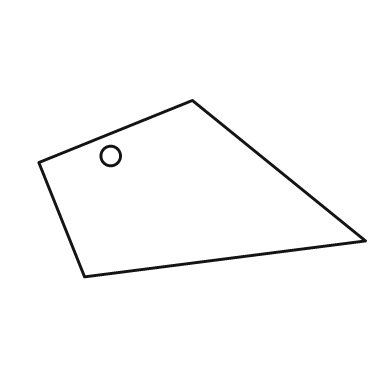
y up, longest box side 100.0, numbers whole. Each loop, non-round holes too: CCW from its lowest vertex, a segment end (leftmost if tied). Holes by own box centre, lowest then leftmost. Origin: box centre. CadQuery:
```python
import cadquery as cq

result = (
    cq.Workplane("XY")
    .moveTo(-36.0, -27.0)
    .lineTo(50.0, -16.0)
    .lineTo(-3.0, 27.0)
    .lineTo(-50.0, 8.0)
    .close()
    .moveTo(-28.0, 10.0)
    .circle(3.0)
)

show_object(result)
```